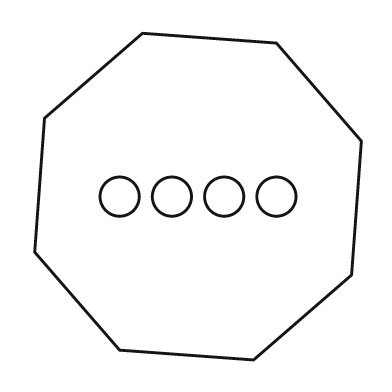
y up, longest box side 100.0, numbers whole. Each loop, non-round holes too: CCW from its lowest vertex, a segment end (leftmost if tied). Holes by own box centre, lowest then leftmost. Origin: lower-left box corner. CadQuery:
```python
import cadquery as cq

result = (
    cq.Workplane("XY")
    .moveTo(67.0, 0.0)
    .lineTo(97.0, 26.0)
    .lineTo(100.0, 67.0)
    .lineTo(74.0, 97.0)
    .lineTo(33.0, 100.0)
    .lineTo(3.0, 74.0)
    .lineTo(0.0, 33.0)
    .lineTo(26.0, 3.0)
    .close()
    .moveTo(26.0, 50.0)
    .circle(6.0)
    .moveTo(42.0, 50.0)
    .circle(6.0)
    .moveTo(58.0, 50.0)
    .circle(6.0)
    .moveTo(74.0, 50.0)
    .circle(6.0)
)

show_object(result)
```